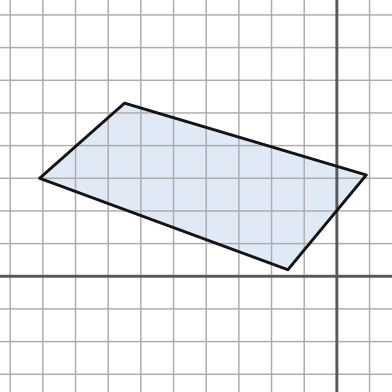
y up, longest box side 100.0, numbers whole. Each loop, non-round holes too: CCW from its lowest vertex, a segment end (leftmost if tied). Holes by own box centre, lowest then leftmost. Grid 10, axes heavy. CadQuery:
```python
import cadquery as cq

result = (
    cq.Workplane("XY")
    .moveTo(-15.0, 2.0)
    .lineTo(9.0, 31.0)
    .lineTo(-65.0, 53.0)
    .lineTo(-91.0, 30.0)
    .close()
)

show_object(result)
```